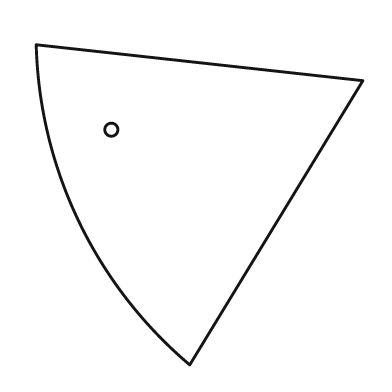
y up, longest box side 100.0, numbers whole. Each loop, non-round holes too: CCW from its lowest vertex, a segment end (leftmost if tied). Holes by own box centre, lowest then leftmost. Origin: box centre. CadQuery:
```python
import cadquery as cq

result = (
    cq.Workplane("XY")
    .moveTo(-3.0, -49.0)
    .lineTo(50.0, 38.0)
    .lineTo(-50.0, 49.0)
    .threePointArc((-37.0, -5.0), (-3.0, -49.0))
    .close()
    .moveTo(-27.0, 23.0)
    .circle(2.0)
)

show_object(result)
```